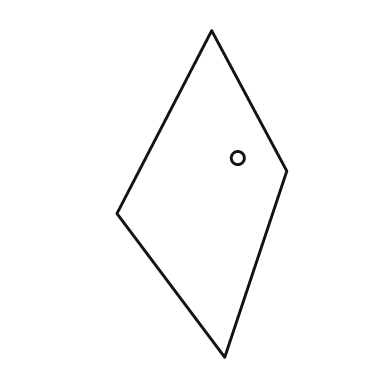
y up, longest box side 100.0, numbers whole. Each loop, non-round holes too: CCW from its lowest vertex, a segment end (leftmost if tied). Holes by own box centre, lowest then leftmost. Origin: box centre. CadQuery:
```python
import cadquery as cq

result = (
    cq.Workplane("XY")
    .moveTo(7.0, -50.0)
    .lineTo(26.0, 7.0)
    .lineTo(3.0, 50.0)
    .lineTo(-26.0, -6.0)
    .close()
    .moveTo(11.0, 11.0)
    .circle(2.0)
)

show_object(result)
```